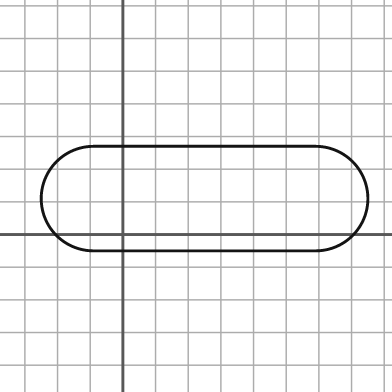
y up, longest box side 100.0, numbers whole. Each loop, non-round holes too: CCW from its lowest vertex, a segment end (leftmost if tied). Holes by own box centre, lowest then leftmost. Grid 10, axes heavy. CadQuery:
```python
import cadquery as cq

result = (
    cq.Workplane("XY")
    .moveTo(-9.0, -5.0)
    .lineTo(59.0, -5.0)
    .threePointArc((75.0, 11.0), (59.0, 27.0))
    .lineTo(-9.0, 27.0)
    .threePointArc((-25.0, 11.0), (-9.0, -5.0))
    .close()
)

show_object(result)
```